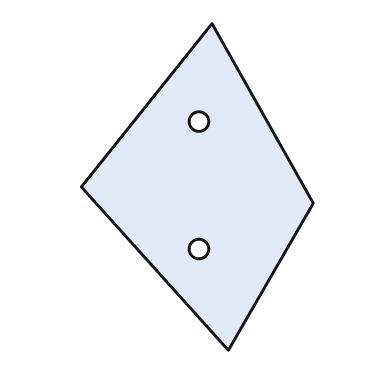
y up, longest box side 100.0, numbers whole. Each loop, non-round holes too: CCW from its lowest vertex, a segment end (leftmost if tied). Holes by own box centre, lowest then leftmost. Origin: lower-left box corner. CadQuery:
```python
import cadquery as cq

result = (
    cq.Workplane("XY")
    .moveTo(45.0, 0.0)
    .lineTo(71.0, 45.0)
    .lineTo(40.0, 100.0)
    .lineTo(0.0, 50.0)
    .close()
    .moveTo(36.0, 31.0)
    .circle(3.0)
    .moveTo(36.0, 70.0)
    .circle(3.0)
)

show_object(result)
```